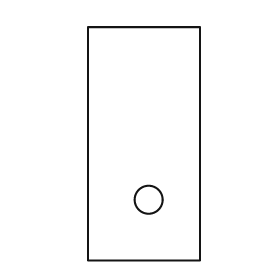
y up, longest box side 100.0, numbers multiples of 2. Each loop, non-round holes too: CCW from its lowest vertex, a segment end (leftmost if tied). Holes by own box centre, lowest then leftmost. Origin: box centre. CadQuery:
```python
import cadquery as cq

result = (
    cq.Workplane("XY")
    .moveTo(-24.0, -50.0)
    .lineTo(24.0, -50.0)
    .lineTo(24.0, 50.0)
    .lineTo(-24.0, 50.0)
    .close()
    .moveTo(2.0, -24.0)
    .circle(6.0)
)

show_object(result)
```